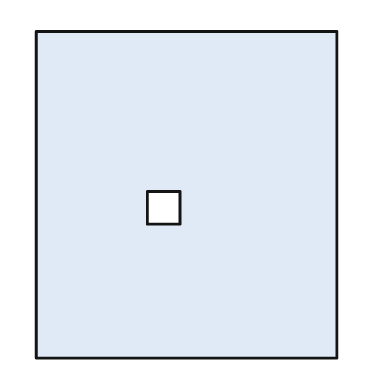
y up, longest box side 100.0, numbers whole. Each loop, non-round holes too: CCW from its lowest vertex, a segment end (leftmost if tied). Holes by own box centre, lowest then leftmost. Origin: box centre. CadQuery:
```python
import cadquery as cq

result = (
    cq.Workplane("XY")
    .moveTo(-46.0, -50.0)
    .lineTo(46.0, -50.0)
    .lineTo(46.0, 50.0)
    .lineTo(-46.0, 50.0)
    .close()
    .moveTo(-12.0, -9.0)
    .lineTo(-2.0, -9.0)
    .lineTo(-2.0, 1.0)
    .lineTo(-12.0, 1.0)
    .close()
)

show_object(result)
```